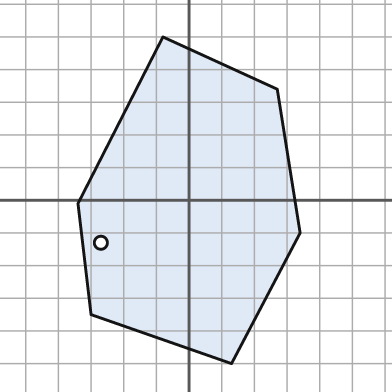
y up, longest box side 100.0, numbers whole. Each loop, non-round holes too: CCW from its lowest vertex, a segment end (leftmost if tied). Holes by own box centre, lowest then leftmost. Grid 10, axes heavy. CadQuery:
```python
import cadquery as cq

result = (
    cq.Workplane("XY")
    .moveTo(13.0, -50.0)
    .lineTo(34.0, -10.0)
    .lineTo(27.0, 34.0)
    .lineTo(-8.0, 50.0)
    .lineTo(-34.0, -1.0)
    .lineTo(-30.0, -35.0)
    .close()
    .moveTo(-27.0, -13.0)
    .circle(2.0)
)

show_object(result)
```